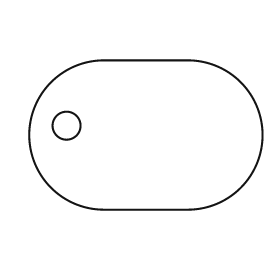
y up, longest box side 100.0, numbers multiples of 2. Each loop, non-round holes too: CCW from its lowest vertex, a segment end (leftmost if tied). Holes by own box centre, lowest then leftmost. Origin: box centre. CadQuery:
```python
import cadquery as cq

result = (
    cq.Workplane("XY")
    .moveTo(-18.0, -32.0)
    .lineTo(18.0, -32.0)
    .threePointArc((50.0, 0.0), (18.0, 32.0))
    .lineTo(-18.0, 32.0)
    .threePointArc((-50.0, 0.0), (-18.0, -32.0))
    .close()
    .moveTo(-34.0, 4.0)
    .circle(6.0)
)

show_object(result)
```